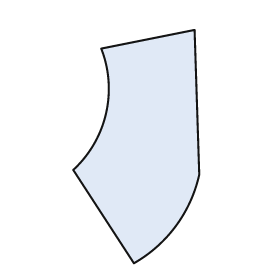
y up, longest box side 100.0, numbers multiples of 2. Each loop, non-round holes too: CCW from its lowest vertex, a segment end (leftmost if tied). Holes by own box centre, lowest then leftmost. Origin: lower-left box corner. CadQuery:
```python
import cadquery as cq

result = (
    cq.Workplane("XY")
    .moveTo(26.0, 0.0)
    .threePointArc((44.0, 16.0), (54.0, 38.0))
    .lineTo(52.0, 100.0)
    .lineTo(12.0, 92.0)
    .threePointArc((14.0, 64.0), (0.0, 40.0))
    .close()
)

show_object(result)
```